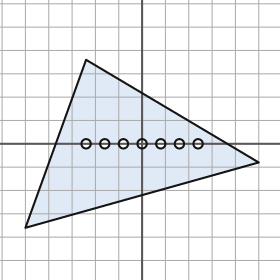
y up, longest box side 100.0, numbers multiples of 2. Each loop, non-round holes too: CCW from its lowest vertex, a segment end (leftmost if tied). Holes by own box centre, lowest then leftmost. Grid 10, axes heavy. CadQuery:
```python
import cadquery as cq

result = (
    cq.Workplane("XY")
    .moveTo(-50.0, -36.0)
    .lineTo(50.0, -8.0)
    .lineTo(-24.0, 36.0)
    .close()
    .moveTo(-24.0, 0.0)
    .circle(2.0)
    .moveTo(-16.0, 0.0)
    .circle(2.0)
    .moveTo(-8.0, 0.0)
    .circle(2.0)
    .moveTo(0.0, 0.0)
    .circle(2.0)
    .moveTo(8.0, 0.0)
    .circle(2.0)
    .moveTo(16.0, 0.0)
    .circle(2.0)
    .moveTo(24.0, 0.0)
    .circle(2.0)
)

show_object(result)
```